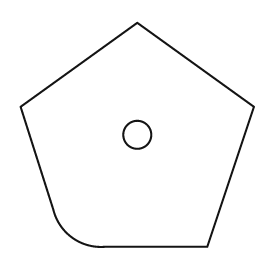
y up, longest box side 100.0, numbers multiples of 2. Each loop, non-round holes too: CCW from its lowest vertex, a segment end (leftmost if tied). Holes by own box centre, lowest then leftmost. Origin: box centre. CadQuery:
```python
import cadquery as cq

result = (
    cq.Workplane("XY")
    .moveTo(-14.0, -48.0)
    .lineTo(30.0, -48.0)
    .lineTo(50.0, 12.0)
    .lineTo(0.0, 48.0)
    .lineTo(-50.0, 12.0)
    .lineTo(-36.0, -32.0)
    .threePointArc((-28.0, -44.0), (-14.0, -48.0))
    .close()
    .moveTo(0.0, 0.0)
    .circle(6.0)
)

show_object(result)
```